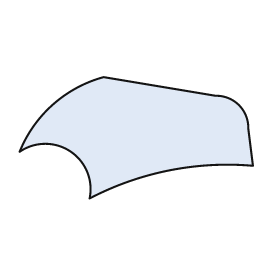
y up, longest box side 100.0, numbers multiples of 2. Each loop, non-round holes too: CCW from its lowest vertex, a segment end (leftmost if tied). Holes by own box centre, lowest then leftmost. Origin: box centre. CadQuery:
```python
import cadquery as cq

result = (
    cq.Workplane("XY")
    .moveTo(-20.0, -26.0)
    .threePointArc((14.0, -14.0), (50.0, -12.0))
    .lineTo(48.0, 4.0)
    .threePointArc((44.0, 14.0), (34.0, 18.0))
    .lineTo(-14.0, 26.0)
    .threePointArc((-36.0, 14.0), (-50.0, -6.0))
    .threePointArc((-28.0, -6.0), (-20.0, -26.0))
    .close()
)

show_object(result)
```